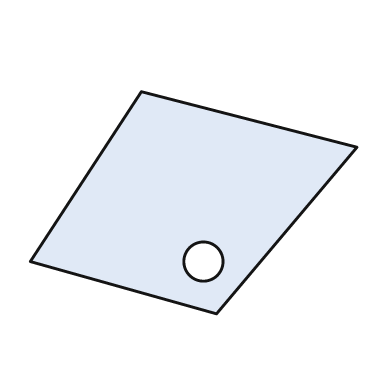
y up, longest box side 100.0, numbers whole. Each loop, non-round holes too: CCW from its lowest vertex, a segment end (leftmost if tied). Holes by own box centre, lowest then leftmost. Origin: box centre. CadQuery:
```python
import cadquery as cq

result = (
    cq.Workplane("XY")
    .moveTo(7.0, -34.0)
    .lineTo(50.0, 17.0)
    .lineTo(-16.0, 34.0)
    .lineTo(-50.0, -18.0)
    .close()
    .moveTo(3.0, -18.0)
    .circle(6.0)
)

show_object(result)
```